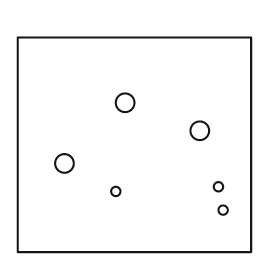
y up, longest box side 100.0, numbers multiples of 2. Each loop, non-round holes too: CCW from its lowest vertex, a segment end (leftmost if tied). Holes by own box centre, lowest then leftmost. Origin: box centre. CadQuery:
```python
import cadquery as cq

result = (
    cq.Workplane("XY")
    .moveTo(-50.0, -46.0)
    .lineTo(50.0, -46.0)
    .lineTo(50.0, 46.0)
    .lineTo(-50.0, 46.0)
    .close()
    .moveTo(38.0, -28.0)
    .circle(2.0)
    .moveTo(-8.0, -20.0)
    .circle(2.0)
    .moveTo(36.0, -18.0)
    .circle(2.0)
    .moveTo(-30.0, -8.0)
    .circle(4.0)
    .moveTo(28.0, 6.0)
    .circle(4.0)
    .moveTo(-4.0, 18.0)
    .circle(4.0)
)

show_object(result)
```